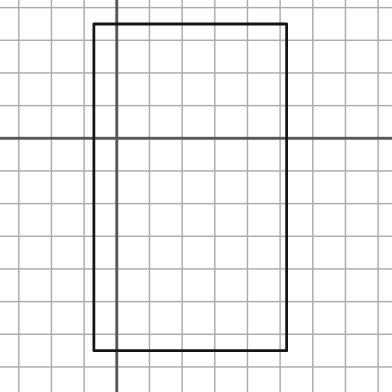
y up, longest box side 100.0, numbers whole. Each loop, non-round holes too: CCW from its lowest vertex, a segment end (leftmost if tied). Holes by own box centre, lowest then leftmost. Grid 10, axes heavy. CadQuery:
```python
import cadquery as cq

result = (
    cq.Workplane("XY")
    .moveTo(-7.0, -65.0)
    .lineTo(52.0, -65.0)
    .lineTo(52.0, 35.0)
    .lineTo(-7.0, 35.0)
    .close()
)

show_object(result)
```